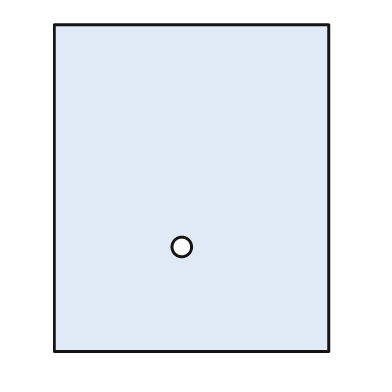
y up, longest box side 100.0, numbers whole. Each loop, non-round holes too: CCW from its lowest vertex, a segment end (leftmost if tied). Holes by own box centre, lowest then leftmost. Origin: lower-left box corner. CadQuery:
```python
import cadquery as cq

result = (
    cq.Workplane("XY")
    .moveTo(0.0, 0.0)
    .lineTo(84.0, 0.0)
    .lineTo(84.0, 100.0)
    .lineTo(0.0, 100.0)
    .close()
    .moveTo(39.0, 32.0)
    .circle(3.0)
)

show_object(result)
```